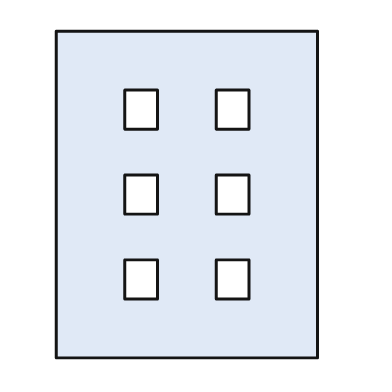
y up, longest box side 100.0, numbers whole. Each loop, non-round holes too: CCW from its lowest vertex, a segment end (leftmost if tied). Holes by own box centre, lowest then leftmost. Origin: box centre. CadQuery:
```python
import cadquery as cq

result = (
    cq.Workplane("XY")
    .moveTo(-40.0, -50.0)
    .lineTo(40.0, -50.0)
    .lineTo(40.0, 50.0)
    .lineTo(-40.0, 50.0)
    .close()
    .moveTo(-19.0, -32.0)
    .lineTo(-9.0, -32.0)
    .lineTo(-9.0, -20.0)
    .lineTo(-19.0, -20.0)
    .close()
    .moveTo(9.0, -32.0)
    .lineTo(19.0, -32.0)
    .lineTo(19.0, -20.0)
    .lineTo(9.0, -20.0)
    .close()
    .moveTo(-19.0, -6.0)
    .lineTo(-9.0, -6.0)
    .lineTo(-9.0, 6.0)
    .lineTo(-19.0, 6.0)
    .close()
    .moveTo(9.0, -6.0)
    .lineTo(19.0, -6.0)
    .lineTo(19.0, 6.0)
    .lineTo(9.0, 6.0)
    .close()
    .moveTo(-19.0, 20.0)
    .lineTo(-9.0, 20.0)
    .lineTo(-9.0, 32.0)
    .lineTo(-19.0, 32.0)
    .close()
    .moveTo(9.0, 20.0)
    .lineTo(19.0, 20.0)
    .lineTo(19.0, 32.0)
    .lineTo(9.0, 32.0)
    .close()
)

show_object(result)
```